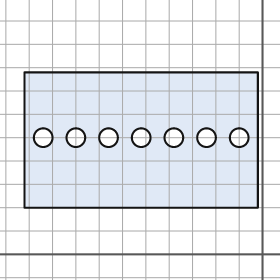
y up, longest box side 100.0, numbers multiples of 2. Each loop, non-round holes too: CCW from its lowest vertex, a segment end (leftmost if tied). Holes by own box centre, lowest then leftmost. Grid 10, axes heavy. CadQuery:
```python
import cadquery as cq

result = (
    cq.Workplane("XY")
    .moveTo(-102.0, 20.0)
    .lineTo(-2.0, 20.0)
    .lineTo(-2.0, 78.0)
    .lineTo(-102.0, 78.0)
    .close()
    .moveTo(-94.0, 50.0)
    .circle(4.0)
    .moveTo(-80.0, 50.0)
    .circle(4.0)
    .moveTo(-66.0, 50.0)
    .circle(4.0)
    .moveTo(-52.0, 50.0)
    .circle(4.0)
    .moveTo(-38.0, 50.0)
    .circle(4.0)
    .moveTo(-24.0, 50.0)
    .circle(4.0)
    .moveTo(-10.0, 50.0)
    .circle(4.0)
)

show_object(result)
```